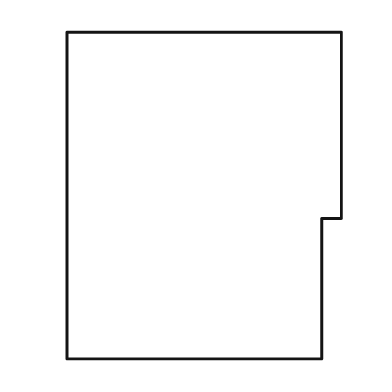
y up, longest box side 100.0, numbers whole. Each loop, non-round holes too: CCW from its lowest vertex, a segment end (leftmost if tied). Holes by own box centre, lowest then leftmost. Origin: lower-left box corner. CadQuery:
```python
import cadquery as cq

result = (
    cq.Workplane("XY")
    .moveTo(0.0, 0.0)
    .lineTo(78.0, 0.0)
    .lineTo(78.0, 43.0)
    .lineTo(84.0, 43.0)
    .lineTo(84.0, 100.0)
    .lineTo(0.0, 100.0)
    .close()
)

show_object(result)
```